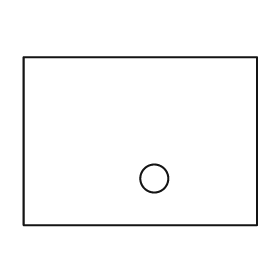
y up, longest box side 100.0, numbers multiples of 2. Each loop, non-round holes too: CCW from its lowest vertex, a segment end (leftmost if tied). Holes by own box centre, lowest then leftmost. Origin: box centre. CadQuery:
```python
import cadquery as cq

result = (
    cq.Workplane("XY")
    .moveTo(-50.0, -36.0)
    .lineTo(50.0, -36.0)
    .lineTo(50.0, 36.0)
    .lineTo(-50.0, 36.0)
    .close()
    .moveTo(6.0, -16.0)
    .circle(6.0)
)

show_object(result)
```